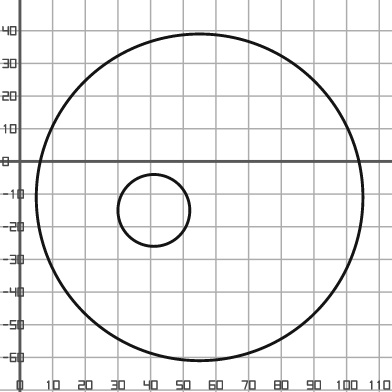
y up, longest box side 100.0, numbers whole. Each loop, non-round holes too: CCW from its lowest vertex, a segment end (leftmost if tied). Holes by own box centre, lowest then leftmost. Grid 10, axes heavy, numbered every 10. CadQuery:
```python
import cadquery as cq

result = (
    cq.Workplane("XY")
    .moveTo(55.0, -11.0)
    .circle(50.0)
    .moveTo(41.0, -15.0)
    .circle(11.0)
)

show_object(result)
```